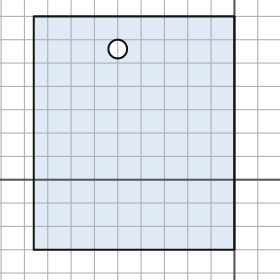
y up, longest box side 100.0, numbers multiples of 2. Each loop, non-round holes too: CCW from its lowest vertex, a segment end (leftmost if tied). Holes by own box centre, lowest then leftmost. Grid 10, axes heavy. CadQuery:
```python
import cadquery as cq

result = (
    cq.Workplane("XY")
    .moveTo(-86.0, -30.0)
    .lineTo(0.0, -30.0)
    .lineTo(0.0, 70.0)
    .lineTo(-86.0, 70.0)
    .close()
    .moveTo(-50.0, 56.0)
    .circle(4.0)
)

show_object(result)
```